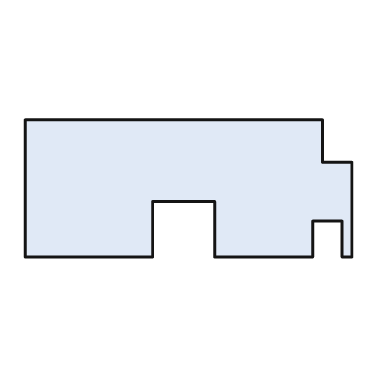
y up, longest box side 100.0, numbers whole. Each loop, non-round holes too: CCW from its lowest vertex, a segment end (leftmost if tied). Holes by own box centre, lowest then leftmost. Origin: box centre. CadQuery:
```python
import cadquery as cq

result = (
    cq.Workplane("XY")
    .moveTo(-50.0, -21.0)
    .lineTo(-11.0, -21.0)
    .lineTo(-11.0, -4.0)
    .lineTo(8.0, -4.0)
    .lineTo(8.0, -21.0)
    .lineTo(38.0, -21.0)
    .lineTo(38.0, -10.0)
    .lineTo(47.0, -10.0)
    .lineTo(47.0, -21.0)
    .lineTo(50.0, -21.0)
    .lineTo(50.0, 8.0)
    .lineTo(41.0, 8.0)
    .lineTo(41.0, 21.0)
    .lineTo(-50.0, 21.0)
    .close()
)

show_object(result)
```